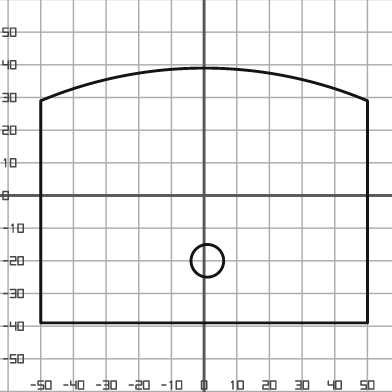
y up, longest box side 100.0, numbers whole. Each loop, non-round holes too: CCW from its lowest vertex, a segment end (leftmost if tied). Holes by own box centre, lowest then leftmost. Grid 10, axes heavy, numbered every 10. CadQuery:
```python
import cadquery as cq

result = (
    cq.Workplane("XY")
    .moveTo(-50.0, -39.0)
    .lineTo(50.0, -39.0)
    .lineTo(50.0, 29.0)
    .threePointArc((0.0, 39.0), (-50.0, 29.0))
    .close()
    .moveTo(1.0, -20.0)
    .circle(5.0)
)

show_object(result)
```